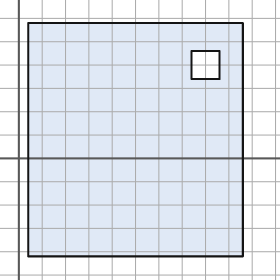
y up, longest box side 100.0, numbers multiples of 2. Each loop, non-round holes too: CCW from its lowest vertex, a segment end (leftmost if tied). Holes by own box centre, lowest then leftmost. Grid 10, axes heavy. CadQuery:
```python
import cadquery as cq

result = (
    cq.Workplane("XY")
    .moveTo(4.0, -42.0)
    .lineTo(96.0, -42.0)
    .lineTo(96.0, 58.0)
    .lineTo(4.0, 58.0)
    .close()
    .moveTo(74.0, 34.0)
    .lineTo(86.0, 34.0)
    .lineTo(86.0, 46.0)
    .lineTo(74.0, 46.0)
    .close()
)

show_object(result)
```